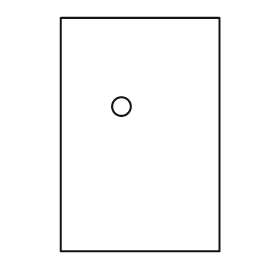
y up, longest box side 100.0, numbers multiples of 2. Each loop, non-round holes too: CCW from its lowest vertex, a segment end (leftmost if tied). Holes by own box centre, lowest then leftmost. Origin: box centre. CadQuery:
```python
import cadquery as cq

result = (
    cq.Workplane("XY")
    .moveTo(-34.0, -50.0)
    .lineTo(34.0, -50.0)
    .lineTo(34.0, 50.0)
    .lineTo(-34.0, 50.0)
    .close()
    .moveTo(-8.0, 12.0)
    .circle(4.0)
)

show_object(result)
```